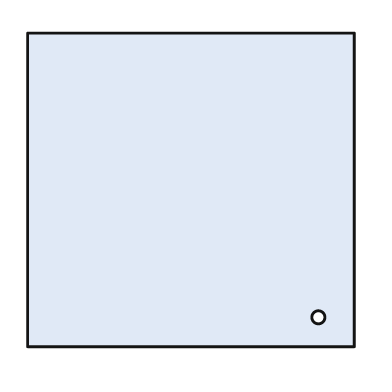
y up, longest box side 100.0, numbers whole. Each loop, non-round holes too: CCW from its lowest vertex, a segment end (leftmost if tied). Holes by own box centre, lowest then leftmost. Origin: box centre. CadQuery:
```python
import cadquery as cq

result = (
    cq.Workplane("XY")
    .moveTo(-50.0, -48.0)
    .lineTo(50.0, -48.0)
    .lineTo(50.0, 48.0)
    .lineTo(-50.0, 48.0)
    .close()
    .moveTo(39.0, -39.0)
    .circle(2.0)
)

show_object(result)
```